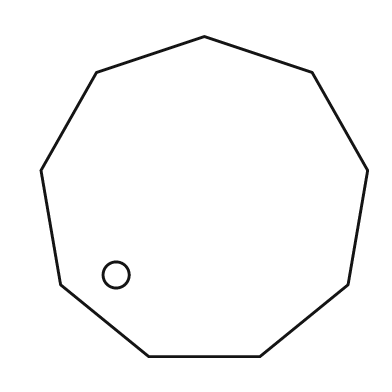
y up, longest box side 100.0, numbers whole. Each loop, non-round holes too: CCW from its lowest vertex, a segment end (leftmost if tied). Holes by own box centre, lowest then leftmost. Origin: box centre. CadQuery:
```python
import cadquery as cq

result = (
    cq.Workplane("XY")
    .moveTo(-17.0, -49.0)
    .lineTo(17.0, -49.0)
    .lineTo(44.0, -27.0)
    .lineTo(50.0, 8.0)
    .lineTo(33.0, 38.0)
    .lineTo(0.0, 49.0)
    .lineTo(-33.0, 38.0)
    .lineTo(-50.0, 8.0)
    .lineTo(-44.0, -27.0)
    .close()
    .moveTo(-27.0, -24.0)
    .circle(4.0)
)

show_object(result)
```